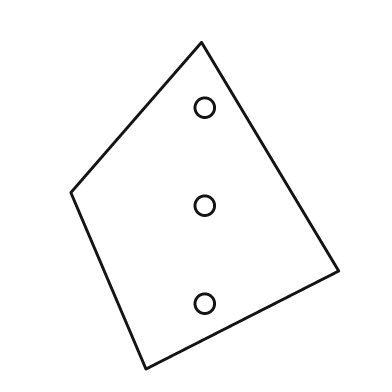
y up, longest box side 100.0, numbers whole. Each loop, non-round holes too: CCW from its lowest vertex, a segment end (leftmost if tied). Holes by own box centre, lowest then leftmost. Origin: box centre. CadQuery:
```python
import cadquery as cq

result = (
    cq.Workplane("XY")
    .moveTo(-18.0, -50.0)
    .lineTo(41.0, -20.0)
    .lineTo(-1.0, 50.0)
    .lineTo(-41.0, 4.0)
    .close()
    .moveTo(0.0, -30.0)
    .circle(3.0)
    .moveTo(0.0, 0.0)
    .circle(3.0)
    .moveTo(0.0, 30.0)
    .circle(3.0)
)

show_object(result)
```